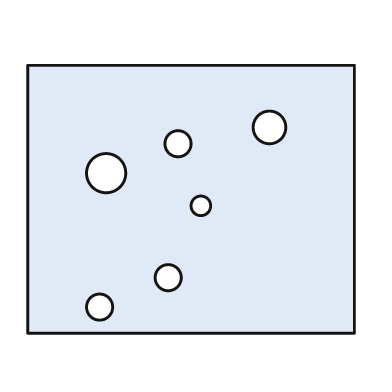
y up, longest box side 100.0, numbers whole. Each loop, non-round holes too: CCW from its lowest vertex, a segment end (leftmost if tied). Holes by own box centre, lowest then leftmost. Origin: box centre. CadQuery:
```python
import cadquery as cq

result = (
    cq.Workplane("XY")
    .moveTo(-50.0, -41.0)
    .lineTo(50.0, -41.0)
    .lineTo(50.0, 41.0)
    .lineTo(-50.0, 41.0)
    .close()
    .moveTo(-28.0, -33.0)
    .circle(4.0)
    .moveTo(-7.0, -24.0)
    .circle(4.0)
    .moveTo(3.0, -2.0)
    .circle(3.0)
    .moveTo(-26.0, 8.0)
    .circle(6.0)
    .moveTo(-4.0, 17.0)
    .circle(4.0)
    .moveTo(24.0, 22.0)
    .circle(5.0)
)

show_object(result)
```